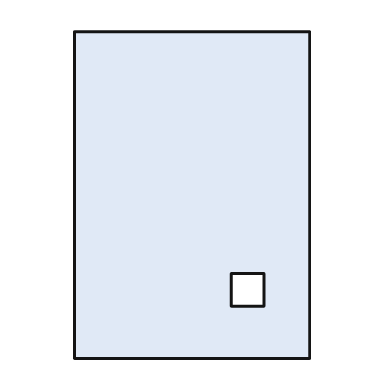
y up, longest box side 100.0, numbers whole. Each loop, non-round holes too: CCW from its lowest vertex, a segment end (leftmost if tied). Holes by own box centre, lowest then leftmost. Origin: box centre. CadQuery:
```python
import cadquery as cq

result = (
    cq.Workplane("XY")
    .moveTo(-36.0, -50.0)
    .lineTo(36.0, -50.0)
    .lineTo(36.0, 50.0)
    .lineTo(-36.0, 50.0)
    .close()
    .moveTo(12.0, -34.0)
    .lineTo(22.0, -34.0)
    .lineTo(22.0, -24.0)
    .lineTo(12.0, -24.0)
    .close()
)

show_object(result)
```